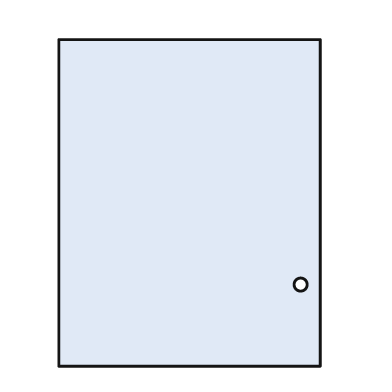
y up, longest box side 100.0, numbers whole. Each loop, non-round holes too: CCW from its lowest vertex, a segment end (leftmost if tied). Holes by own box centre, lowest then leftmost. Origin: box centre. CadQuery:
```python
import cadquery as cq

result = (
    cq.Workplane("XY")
    .moveTo(-40.0, -50.0)
    .lineTo(40.0, -50.0)
    .lineTo(40.0, 50.0)
    .lineTo(-40.0, 50.0)
    .close()
    .moveTo(34.0, -25.0)
    .circle(2.0)
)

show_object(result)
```